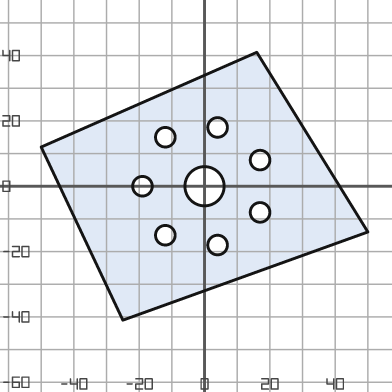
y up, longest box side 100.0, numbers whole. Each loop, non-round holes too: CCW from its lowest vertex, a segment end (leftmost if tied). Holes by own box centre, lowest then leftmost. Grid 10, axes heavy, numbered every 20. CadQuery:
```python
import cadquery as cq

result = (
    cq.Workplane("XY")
    .moveTo(-25.0, -41.0)
    .lineTo(50.0, -14.0)
    .lineTo(16.0, 41.0)
    .lineTo(-50.0, 12.0)
    .close()
    .moveTo(4.0, -18.0)
    .circle(3.0)
    .moveTo(-12.0, -15.0)
    .circle(3.0)
    .moveTo(17.0, -8.0)
    .circle(3.0)
    .moveTo(-19.0, 0.0)
    .circle(3.0)
    .moveTo(0.0, 0.0)
    .circle(6.0)
    .moveTo(17.0, 8.0)
    .circle(3.0)
    .moveTo(-12.0, 15.0)
    .circle(3.0)
    .moveTo(4.0, 18.0)
    .circle(3.0)
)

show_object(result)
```